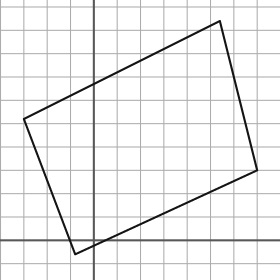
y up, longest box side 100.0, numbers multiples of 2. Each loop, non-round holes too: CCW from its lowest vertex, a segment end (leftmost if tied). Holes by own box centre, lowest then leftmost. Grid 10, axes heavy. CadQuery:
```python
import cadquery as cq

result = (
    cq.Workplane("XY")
    .moveTo(-8.0, -6.0)
    .lineTo(70.0, 30.0)
    .lineTo(54.0, 94.0)
    .lineTo(-30.0, 52.0)
    .close()
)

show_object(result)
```